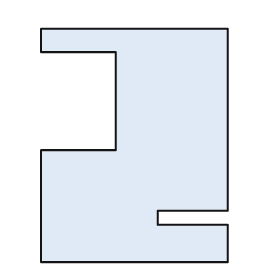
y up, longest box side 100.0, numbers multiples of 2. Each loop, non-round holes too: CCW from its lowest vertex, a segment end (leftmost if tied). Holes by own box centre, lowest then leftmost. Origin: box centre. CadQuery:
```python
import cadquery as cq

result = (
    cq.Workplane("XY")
    .moveTo(-40.0, -50.0)
    .lineTo(40.0, -50.0)
    .lineTo(40.0, -34.0)
    .lineTo(10.0, -34.0)
    .lineTo(10.0, -28.0)
    .lineTo(40.0, -28.0)
    .lineTo(40.0, 50.0)
    .lineTo(-40.0, 50.0)
    .lineTo(-40.0, 40.0)
    .lineTo(-8.0, 40.0)
    .lineTo(-8.0, -2.0)
    .lineTo(-40.0, -2.0)
    .close()
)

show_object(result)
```